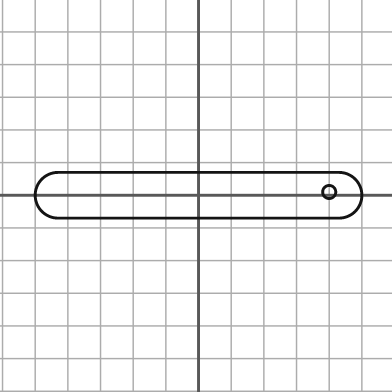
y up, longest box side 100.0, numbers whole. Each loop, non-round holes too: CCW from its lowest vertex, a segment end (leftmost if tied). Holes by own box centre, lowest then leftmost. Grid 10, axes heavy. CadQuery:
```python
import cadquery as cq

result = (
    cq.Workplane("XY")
    .moveTo(-43.0, -7.0)
    .lineTo(43.0, -7.0)
    .threePointArc((50.0, 0.0), (43.0, 7.0))
    .lineTo(-43.0, 7.0)
    .threePointArc((-50.0, 0.0), (-43.0, -7.0))
    .close()
    .moveTo(40.0, 1.0)
    .circle(2.0)
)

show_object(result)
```